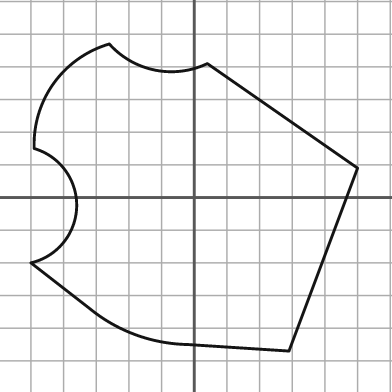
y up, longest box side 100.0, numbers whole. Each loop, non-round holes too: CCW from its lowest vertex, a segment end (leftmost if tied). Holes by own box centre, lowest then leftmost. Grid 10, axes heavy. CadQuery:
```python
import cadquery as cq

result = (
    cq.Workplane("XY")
    .moveTo(29.0, -47.0)
    .lineTo(50.0, 9.0)
    .lineTo(4.0, 41.0)
    .threePointArc((-12.0, 39.0), (-26.0, 47.0))
    .threePointArc((-43.0, 35.0), (-49.0, 15.0))
    .threePointArc((-36.0, -3.0), (-50.0, -20.0))
    .lineTo(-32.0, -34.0)
    .threePointArc((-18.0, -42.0), (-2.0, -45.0))
    .close()
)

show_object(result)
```